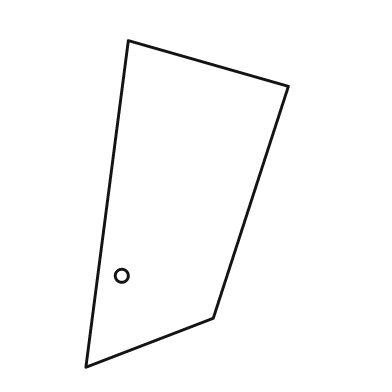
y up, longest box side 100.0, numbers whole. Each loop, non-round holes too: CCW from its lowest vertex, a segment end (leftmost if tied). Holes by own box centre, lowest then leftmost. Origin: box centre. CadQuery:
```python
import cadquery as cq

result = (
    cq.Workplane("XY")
    .moveTo(-31.0, -50.0)
    .lineTo(8.0, -35.0)
    .lineTo(31.0, 36.0)
    .lineTo(-18.0, 50.0)
    .close()
    .moveTo(-20.0, -22.0)
    .circle(2.0)
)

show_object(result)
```